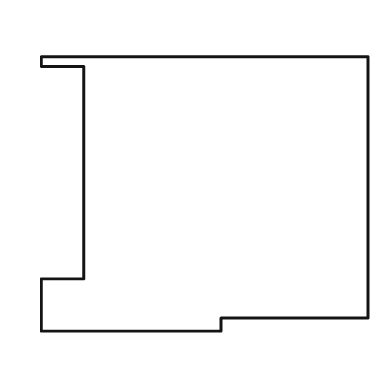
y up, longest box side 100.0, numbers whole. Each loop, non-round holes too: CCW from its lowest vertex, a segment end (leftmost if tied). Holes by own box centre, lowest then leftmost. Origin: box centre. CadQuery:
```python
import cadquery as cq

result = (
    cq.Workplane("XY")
    .moveTo(-50.0, -42.0)
    .lineTo(5.0, -42.0)
    .lineTo(5.0, -38.0)
    .lineTo(50.0, -38.0)
    .lineTo(50.0, 42.0)
    .lineTo(-50.0, 42.0)
    .lineTo(-50.0, 39.0)
    .lineTo(-37.0, 39.0)
    .lineTo(-37.0, -26.0)
    .lineTo(-50.0, -26.0)
    .close()
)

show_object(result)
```